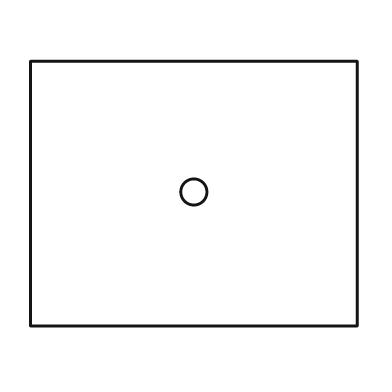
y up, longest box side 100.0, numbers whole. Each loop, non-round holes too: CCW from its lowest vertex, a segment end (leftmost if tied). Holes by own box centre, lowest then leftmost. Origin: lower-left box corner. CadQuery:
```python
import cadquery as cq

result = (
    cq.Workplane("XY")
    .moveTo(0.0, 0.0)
    .lineTo(100.0, 0.0)
    .lineTo(100.0, 81.0)
    .lineTo(0.0, 81.0)
    .close()
    .moveTo(50.0, 41.0)
    .circle(4.0)
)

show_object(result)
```